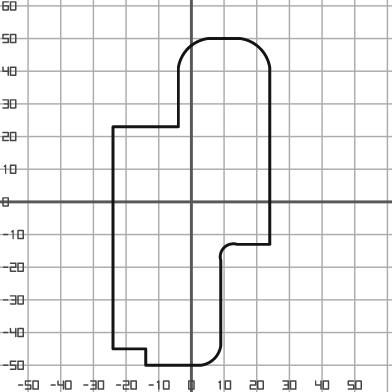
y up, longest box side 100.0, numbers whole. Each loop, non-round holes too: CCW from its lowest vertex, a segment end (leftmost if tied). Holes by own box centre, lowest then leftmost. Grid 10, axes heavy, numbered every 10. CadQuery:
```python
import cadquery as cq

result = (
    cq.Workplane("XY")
    .moveTo(-14.0, -50.0)
    .lineTo(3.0, -50.0)
    .threePointArc((7.0, -48.0), (9.0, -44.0))
    .lineTo(9.0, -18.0)
    .threePointArc((10.0, -14.0), (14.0, -13.0))
    .lineTo(24.0, -13.0)
    .lineTo(24.0, 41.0)
    .threePointArc((21.0, 47.0), (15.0, 50.0))
    .lineTo(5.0, 50.0)
    .threePointArc((-1.0, 47.0), (-4.0, 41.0))
    .lineTo(-4.0, 23.0)
    .lineTo(-24.0, 23.0)
    .lineTo(-24.0, -45.0)
    .lineTo(-14.0, -45.0)
    .close()
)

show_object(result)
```